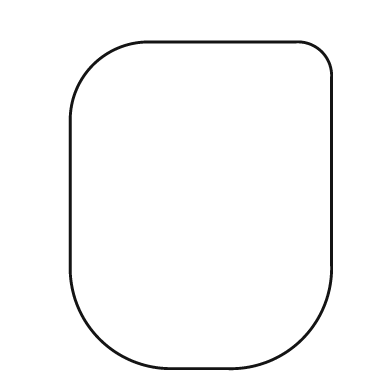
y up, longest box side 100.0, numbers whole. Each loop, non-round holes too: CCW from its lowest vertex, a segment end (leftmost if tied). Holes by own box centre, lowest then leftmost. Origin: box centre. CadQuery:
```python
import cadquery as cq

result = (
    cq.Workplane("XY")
    .moveTo(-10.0, -50.0)
    .lineTo(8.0, -50.0)
    .threePointArc((31.0, -41.0), (40.0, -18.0))
    .lineTo(40.0, 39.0)
    .threePointArc((37.0, 47.0), (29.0, 50.0))
    .lineTo(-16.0, 50.0)
    .threePointArc((-33.0, 43.0), (-40.0, 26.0))
    .lineTo(-40.0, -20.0)
    .threePointArc((-31.0, -41.0), (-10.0, -50.0))
    .close()
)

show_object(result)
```